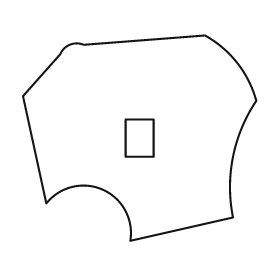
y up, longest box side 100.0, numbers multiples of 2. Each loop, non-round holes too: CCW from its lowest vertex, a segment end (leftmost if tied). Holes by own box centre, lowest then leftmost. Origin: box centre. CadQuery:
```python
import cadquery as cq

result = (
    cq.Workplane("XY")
    .moveTo(-4.0, -44.0)
    .lineTo(40.0, -34.0)
    .threePointArc((40.0, -8.0), (50.0, 16.0))
    .threePointArc((42.0, 32.0), (28.0, 44.0))
    .lineTo(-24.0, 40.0)
    .threePointArc((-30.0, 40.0), (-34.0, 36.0))
    .lineTo(-50.0, 18.0)
    .lineTo(-40.0, -28.0)
    .threePointArc((-16.0, -22.0), (-4.0, -44.0))
    .close()
    .moveTo(-6.0, -8.0)
    .lineTo(6.0, -8.0)
    .lineTo(6.0, 8.0)
    .lineTo(-6.0, 8.0)
    .close()
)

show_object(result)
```